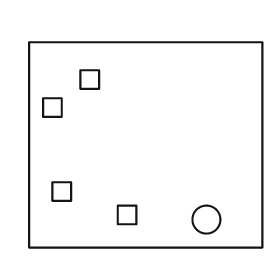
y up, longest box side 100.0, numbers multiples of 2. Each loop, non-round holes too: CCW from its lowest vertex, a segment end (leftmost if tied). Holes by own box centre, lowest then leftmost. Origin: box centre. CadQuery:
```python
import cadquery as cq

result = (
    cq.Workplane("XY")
    .moveTo(-50.0, -44.0)
    .lineTo(50.0, -44.0)
    .lineTo(50.0, 44.0)
    .lineTo(-50.0, 44.0)
    .close()
    .moveTo(26.0, -32.0)
    .circle(6.0)
    .moveTo(-12.0, -34.0)
    .lineTo(-4.0, -34.0)
    .lineTo(-4.0, -26.0)
    .lineTo(-12.0, -26.0)
    .close()
    .moveTo(-40.0, -24.0)
    .lineTo(-32.0, -24.0)
    .lineTo(-32.0, -16.0)
    .lineTo(-40.0, -16.0)
    .close()
    .moveTo(-44.0, 12.0)
    .lineTo(-36.0, 12.0)
    .lineTo(-36.0, 20.0)
    .lineTo(-44.0, 20.0)
    .close()
    .moveTo(-28.0, 24.0)
    .lineTo(-20.0, 24.0)
    .lineTo(-20.0, 32.0)
    .lineTo(-28.0, 32.0)
    .close()
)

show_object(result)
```